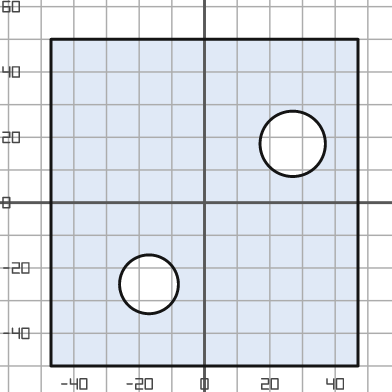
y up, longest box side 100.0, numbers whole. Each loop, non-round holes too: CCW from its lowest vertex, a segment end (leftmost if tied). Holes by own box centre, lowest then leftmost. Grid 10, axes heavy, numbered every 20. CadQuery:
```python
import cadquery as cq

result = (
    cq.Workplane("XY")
    .moveTo(-47.0, -50.0)
    .lineTo(47.0, -50.0)
    .lineTo(47.0, 50.0)
    .lineTo(-47.0, 50.0)
    .close()
    .moveTo(-17.0, -25.0)
    .circle(9.0)
    .moveTo(27.0, 18.0)
    .circle(10.0)
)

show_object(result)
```